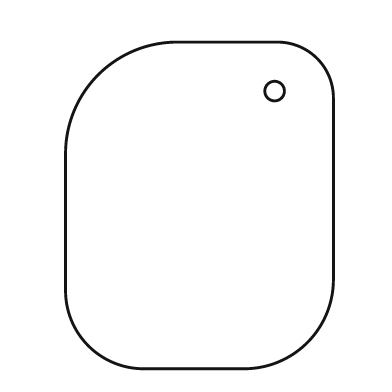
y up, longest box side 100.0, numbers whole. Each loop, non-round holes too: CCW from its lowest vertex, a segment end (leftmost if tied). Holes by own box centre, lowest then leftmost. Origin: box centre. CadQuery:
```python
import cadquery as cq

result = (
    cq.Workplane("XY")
    .moveTo(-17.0, -50.0)
    .lineTo(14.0, -50.0)
    .threePointArc((33.0, -42.0), (41.0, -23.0))
    .lineTo(41.0, 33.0)
    .threePointArc((36.0, 45.0), (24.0, 50.0))
    .lineTo(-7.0, 50.0)
    .threePointArc((-31.0, 40.0), (-41.0, 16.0))
    .lineTo(-41.0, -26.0)
    .threePointArc((-34.0, -43.0), (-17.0, -50.0))
    .close()
    .moveTo(23.0, 35.0)
    .circle(3.0)
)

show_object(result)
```